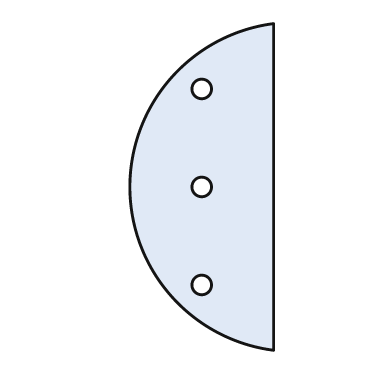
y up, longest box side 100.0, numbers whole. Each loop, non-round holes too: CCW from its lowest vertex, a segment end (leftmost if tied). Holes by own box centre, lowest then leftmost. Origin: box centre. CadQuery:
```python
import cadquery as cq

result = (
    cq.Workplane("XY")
    .moveTo(22.0, -50.0)
    .lineTo(22.0, 50.0)
    .threePointArc((-22.0, 0.0), (22.0, -50.0))
    .close()
    .moveTo(0.0, -30.0)
    .circle(3.0)
    .moveTo(0.0, 0.0)
    .circle(3.0)
    .moveTo(0.0, 30.0)
    .circle(3.0)
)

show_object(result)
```